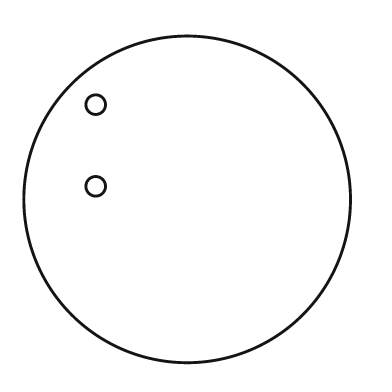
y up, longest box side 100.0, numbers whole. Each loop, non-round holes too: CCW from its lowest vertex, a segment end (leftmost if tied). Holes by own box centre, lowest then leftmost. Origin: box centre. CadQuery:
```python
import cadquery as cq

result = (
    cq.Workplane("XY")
    .moveTo(0.0, 0.0)
    .circle(50.0)
    .moveTo(-28.0, 4.0)
    .circle(3.0)
    .moveTo(-28.0, 29.0)
    .circle(3.0)
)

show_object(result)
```